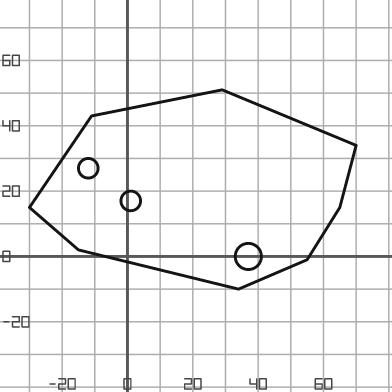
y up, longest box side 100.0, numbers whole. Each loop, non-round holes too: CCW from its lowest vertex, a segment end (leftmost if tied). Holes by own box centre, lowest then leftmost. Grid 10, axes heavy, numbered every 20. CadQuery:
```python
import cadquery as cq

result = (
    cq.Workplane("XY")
    .moveTo(34.0, -10.0)
    .lineTo(55.0, -1.0)
    .lineTo(65.0, 15.0)
    .lineTo(70.0, 34.0)
    .lineTo(29.0, 51.0)
    .lineTo(-11.0, 43.0)
    .lineTo(-30.0, 15.0)
    .lineTo(-15.0, 2.0)
    .close()
    .moveTo(37.0, 0.0)
    .circle(4.0)
    .moveTo(1.0, 17.0)
    .circle(3.0)
    .moveTo(-12.0, 27.0)
    .circle(3.0)
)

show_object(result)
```